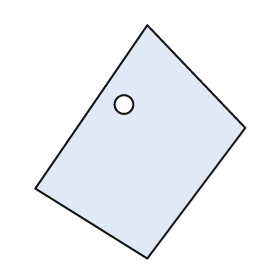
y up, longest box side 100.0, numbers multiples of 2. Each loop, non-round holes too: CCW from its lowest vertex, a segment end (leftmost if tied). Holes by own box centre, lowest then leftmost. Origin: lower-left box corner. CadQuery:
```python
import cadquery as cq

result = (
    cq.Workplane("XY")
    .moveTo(48.0, 0.0)
    .lineTo(90.0, 56.0)
    .lineTo(48.0, 100.0)
    .lineTo(0.0, 30.0)
    .close()
    .moveTo(38.0, 66.0)
    .circle(4.0)
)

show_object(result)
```